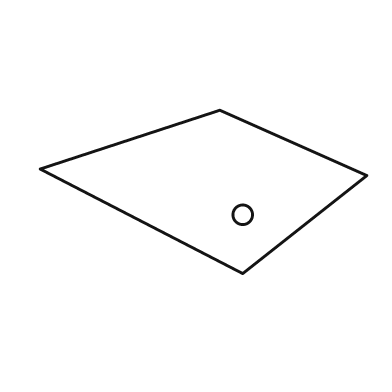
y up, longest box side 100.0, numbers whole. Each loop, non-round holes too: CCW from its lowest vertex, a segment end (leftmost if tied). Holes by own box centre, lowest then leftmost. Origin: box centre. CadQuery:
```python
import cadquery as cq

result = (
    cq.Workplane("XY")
    .moveTo(12.0, -25.0)
    .lineTo(50.0, 5.0)
    .lineTo(5.0, 25.0)
    .lineTo(-50.0, 7.0)
    .close()
    .moveTo(12.0, -7.0)
    .circle(3.0)
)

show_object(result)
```